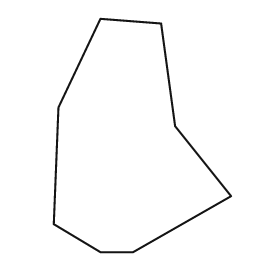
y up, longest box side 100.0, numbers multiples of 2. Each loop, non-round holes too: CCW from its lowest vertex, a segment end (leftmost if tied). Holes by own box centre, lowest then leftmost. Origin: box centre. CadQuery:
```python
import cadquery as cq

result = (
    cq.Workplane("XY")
    .moveTo(-18.0, -50.0)
    .lineTo(-4.0, -50.0)
    .lineTo(38.0, -26.0)
    .lineTo(14.0, 4.0)
    .lineTo(8.0, 48.0)
    .lineTo(-18.0, 50.0)
    .lineTo(-36.0, 12.0)
    .lineTo(-38.0, -38.0)
    .close()
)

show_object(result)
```